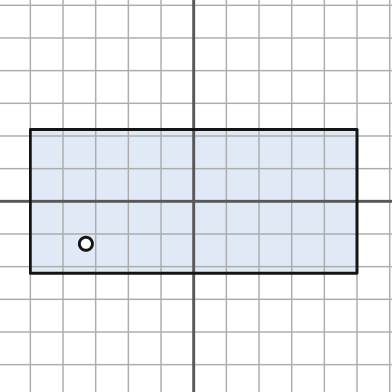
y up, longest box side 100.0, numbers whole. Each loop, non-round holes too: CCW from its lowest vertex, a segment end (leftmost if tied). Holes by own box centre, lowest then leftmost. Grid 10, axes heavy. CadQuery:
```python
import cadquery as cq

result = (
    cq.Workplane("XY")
    .moveTo(-50.0, -22.0)
    .lineTo(50.0, -22.0)
    .lineTo(50.0, 22.0)
    .lineTo(-50.0, 22.0)
    .close()
    .moveTo(-33.0, -13.0)
    .circle(2.0)
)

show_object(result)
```